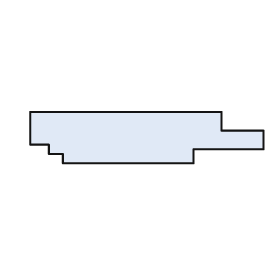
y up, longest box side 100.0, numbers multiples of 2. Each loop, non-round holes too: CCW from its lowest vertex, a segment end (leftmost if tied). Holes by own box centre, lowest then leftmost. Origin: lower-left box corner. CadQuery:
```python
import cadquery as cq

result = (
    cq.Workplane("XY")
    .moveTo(14.0, 0.0)
    .lineTo(70.0, 0.0)
    .lineTo(70.0, 6.0)
    .lineTo(100.0, 6.0)
    .lineTo(100.0, 14.0)
    .lineTo(82.0, 14.0)
    .lineTo(82.0, 22.0)
    .lineTo(0.0, 22.0)
    .lineTo(0.0, 8.0)
    .lineTo(8.0, 8.0)
    .lineTo(8.0, 4.0)
    .lineTo(14.0, 4.0)
    .close()
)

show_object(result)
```